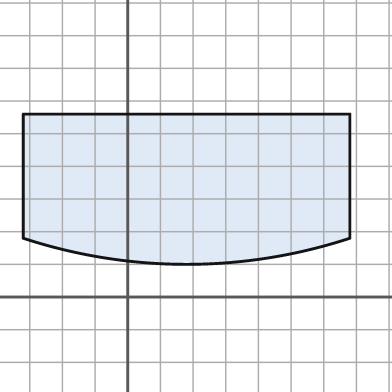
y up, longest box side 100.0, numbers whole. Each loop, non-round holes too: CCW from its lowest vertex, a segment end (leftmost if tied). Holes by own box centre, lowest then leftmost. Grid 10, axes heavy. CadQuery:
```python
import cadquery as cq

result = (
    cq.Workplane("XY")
    .moveTo(-32.0, 18.0)
    .threePointArc((18.0, 10.0), (68.0, 18.0))
    .lineTo(68.0, 56.0)
    .lineTo(-32.0, 56.0)
    .close()
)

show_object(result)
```